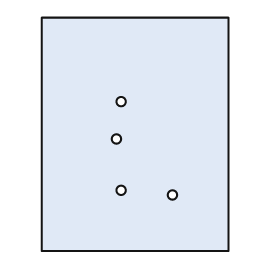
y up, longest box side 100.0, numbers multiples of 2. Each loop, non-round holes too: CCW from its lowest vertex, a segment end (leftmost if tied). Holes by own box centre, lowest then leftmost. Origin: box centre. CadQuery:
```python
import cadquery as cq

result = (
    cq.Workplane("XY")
    .moveTo(-40.0, -50.0)
    .lineTo(40.0, -50.0)
    .lineTo(40.0, 50.0)
    .lineTo(-40.0, 50.0)
    .close()
    .moveTo(16.0, -26.0)
    .circle(2.0)
    .moveTo(-6.0, -24.0)
    .circle(2.0)
    .moveTo(-8.0, -2.0)
    .circle(2.0)
    .moveTo(-6.0, 14.0)
    .circle(2.0)
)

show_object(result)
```